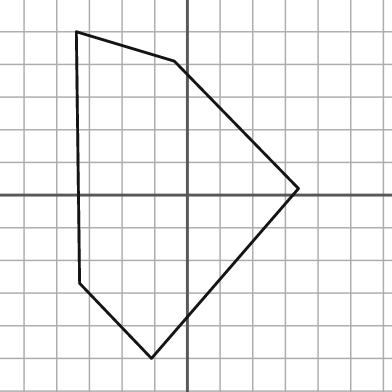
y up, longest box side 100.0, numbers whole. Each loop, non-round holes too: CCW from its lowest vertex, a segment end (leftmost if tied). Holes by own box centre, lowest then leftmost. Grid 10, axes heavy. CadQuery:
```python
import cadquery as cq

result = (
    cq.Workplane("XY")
    .moveTo(-11.0, -50.0)
    .lineTo(34.0, 2.0)
    .lineTo(-4.0, 41.0)
    .lineTo(-34.0, 50.0)
    .lineTo(-33.0, -27.0)
    .close()
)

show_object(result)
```